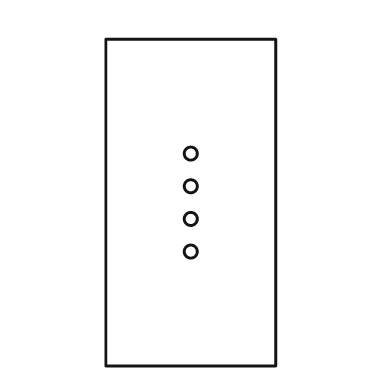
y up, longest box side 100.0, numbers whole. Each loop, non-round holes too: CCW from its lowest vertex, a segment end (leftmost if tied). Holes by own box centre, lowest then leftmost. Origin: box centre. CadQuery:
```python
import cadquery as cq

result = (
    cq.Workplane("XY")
    .moveTo(-26.0, -50.0)
    .lineTo(26.0, -50.0)
    .lineTo(26.0, 50.0)
    .lineTo(-26.0, 50.0)
    .close()
    .moveTo(0.0, -15.0)
    .circle(2.0)
    .moveTo(0.0, -5.0)
    .circle(2.0)
    .moveTo(0.0, 5.0)
    .circle(2.0)
    .moveTo(0.0, 15.0)
    .circle(2.0)
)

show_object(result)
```